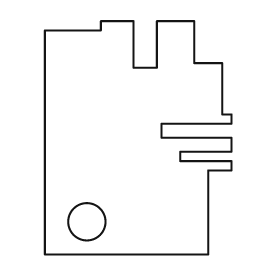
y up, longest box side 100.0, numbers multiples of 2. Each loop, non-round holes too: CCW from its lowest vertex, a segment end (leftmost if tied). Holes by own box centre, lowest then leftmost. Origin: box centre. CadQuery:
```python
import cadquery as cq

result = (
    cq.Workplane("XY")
    .moveTo(-40.0, -50.0)
    .lineTo(30.0, -50.0)
    .lineTo(30.0, -14.0)
    .lineTo(40.0, -14.0)
    .lineTo(40.0, -10.0)
    .lineTo(18.0, -10.0)
    .lineTo(18.0, -6.0)
    .lineTo(40.0, -6.0)
    .lineTo(40.0, 0.0)
    .lineTo(10.0, 0.0)
    .lineTo(10.0, 6.0)
    .lineTo(40.0, 6.0)
    .lineTo(40.0, 10.0)
    .lineTo(36.0, 10.0)
    .lineTo(36.0, 32.0)
    .lineTo(24.0, 32.0)
    .lineTo(24.0, 50.0)
    .lineTo(8.0, 50.0)
    .lineTo(8.0, 30.0)
    .lineTo(-2.0, 30.0)
    .lineTo(-2.0, 50.0)
    .lineTo(-16.0, 50.0)
    .lineTo(-16.0, 46.0)
    .lineTo(-40.0, 46.0)
    .close()
    .moveTo(-22.0, -36.0)
    .circle(8.0)
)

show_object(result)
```